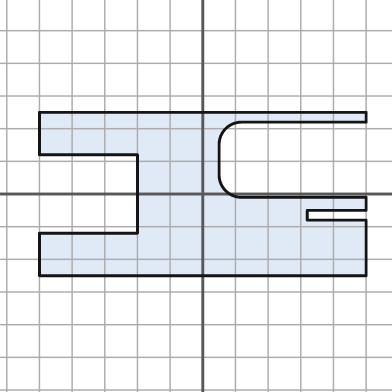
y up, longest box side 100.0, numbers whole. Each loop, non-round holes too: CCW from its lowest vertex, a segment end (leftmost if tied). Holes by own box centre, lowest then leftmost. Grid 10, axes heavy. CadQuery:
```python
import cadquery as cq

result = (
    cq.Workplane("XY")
    .moveTo(-50.0, -25.0)
    .lineTo(50.0, -25.0)
    .lineTo(50.0, -8.0)
    .lineTo(32.0, -8.0)
    .lineTo(32.0, -5.0)
    .lineTo(50.0, -5.0)
    .lineTo(50.0, -1.0)
    .lineTo(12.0, -1.0)
    .threePointArc((7.0, 1.0), (5.0, 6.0))
    .lineTo(5.0, 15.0)
    .threePointArc((7.0, 20.0), (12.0, 22.0))
    .lineTo(50.0, 22.0)
    .lineTo(50.0, 25.0)
    .lineTo(-50.0, 25.0)
    .lineTo(-50.0, 12.0)
    .lineTo(-20.0, 12.0)
    .lineTo(-20.0, -12.0)
    .lineTo(-50.0, -12.0)
    .close()
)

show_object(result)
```